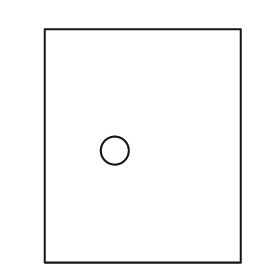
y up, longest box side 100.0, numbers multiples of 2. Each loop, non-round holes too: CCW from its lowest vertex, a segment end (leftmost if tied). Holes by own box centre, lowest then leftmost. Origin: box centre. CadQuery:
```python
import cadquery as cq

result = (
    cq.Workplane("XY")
    .moveTo(-42.0, -50.0)
    .lineTo(42.0, -50.0)
    .lineTo(42.0, 50.0)
    .lineTo(-42.0, 50.0)
    .close()
    .moveTo(-12.0, -2.0)
    .circle(6.0)
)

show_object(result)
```